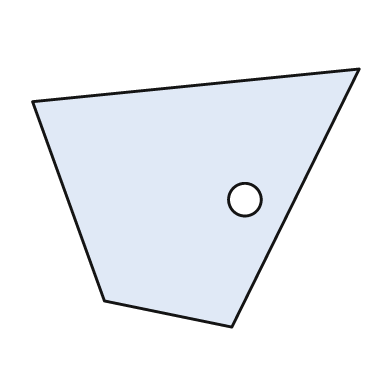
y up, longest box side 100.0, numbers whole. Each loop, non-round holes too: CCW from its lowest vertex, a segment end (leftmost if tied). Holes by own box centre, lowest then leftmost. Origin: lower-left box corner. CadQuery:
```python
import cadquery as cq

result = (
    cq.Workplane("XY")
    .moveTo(61.0, 0.0)
    .lineTo(100.0, 79.0)
    .lineTo(0.0, 69.0)
    .lineTo(22.0, 8.0)
    .close()
    .moveTo(65.0, 39.0)
    .circle(5.0)
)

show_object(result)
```